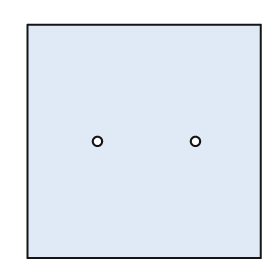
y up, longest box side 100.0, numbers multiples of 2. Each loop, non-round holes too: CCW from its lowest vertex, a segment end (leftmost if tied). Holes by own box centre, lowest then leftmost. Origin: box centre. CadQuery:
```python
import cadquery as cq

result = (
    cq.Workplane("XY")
    .moveTo(-50.0, -50.0)
    .lineTo(50.0, -50.0)
    .lineTo(50.0, 50.0)
    .lineTo(-50.0, 50.0)
    .close()
    .moveTo(-20.0, 0.0)
    .circle(2.0)
    .moveTo(22.0, 0.0)
    .circle(2.0)
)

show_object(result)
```